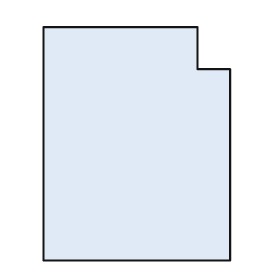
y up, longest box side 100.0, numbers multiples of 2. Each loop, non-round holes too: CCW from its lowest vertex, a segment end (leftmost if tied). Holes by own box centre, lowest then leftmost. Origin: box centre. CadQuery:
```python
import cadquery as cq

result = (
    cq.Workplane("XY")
    .moveTo(-40.0, -50.0)
    .lineTo(40.0, -50.0)
    .lineTo(40.0, 32.0)
    .lineTo(26.0, 32.0)
    .lineTo(26.0, 50.0)
    .lineTo(-40.0, 50.0)
    .close()
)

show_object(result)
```